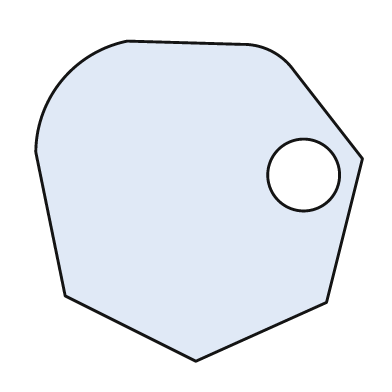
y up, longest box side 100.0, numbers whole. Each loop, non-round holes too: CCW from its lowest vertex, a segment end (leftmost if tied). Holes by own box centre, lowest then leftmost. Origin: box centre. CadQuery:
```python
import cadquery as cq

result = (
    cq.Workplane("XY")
    .moveTo(-1.0, -49.0)
    .lineTo(39.0, -31.0)
    .lineTo(50.0, 13.0)
    .lineTo(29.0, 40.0)
    .threePointArc((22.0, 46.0), (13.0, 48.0))
    .lineTo(-22.0, 49.0)
    .threePointArc((-42.0, 37.0), (-50.0, 15.0))
    .lineTo(-41.0, -29.0)
    .close()
    .moveTo(32.0, 8.0)
    .circle(11.0)
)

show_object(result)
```